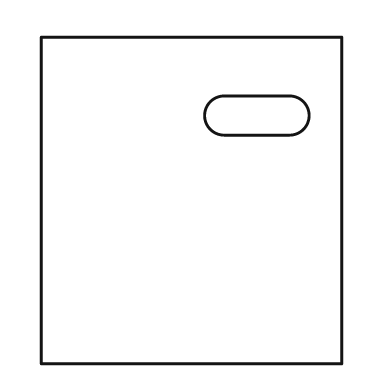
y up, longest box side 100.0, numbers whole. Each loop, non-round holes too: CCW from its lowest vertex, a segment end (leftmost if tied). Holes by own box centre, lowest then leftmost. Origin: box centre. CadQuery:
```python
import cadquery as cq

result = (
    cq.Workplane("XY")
    .moveTo(-46.0, -50.0)
    .lineTo(46.0, -50.0)
    .lineTo(46.0, 50.0)
    .lineTo(-46.0, 50.0)
    .close()
    .moveTo(10.0, 20.0)
    .lineTo(30.0, 20.0)
    .threePointArc((36.0, 26.0), (30.0, 32.0))
    .lineTo(10.0, 32.0)
    .threePointArc((4.0, 26.0), (10.0, 20.0))
    .close()
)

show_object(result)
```